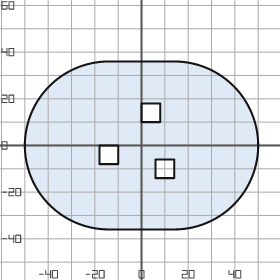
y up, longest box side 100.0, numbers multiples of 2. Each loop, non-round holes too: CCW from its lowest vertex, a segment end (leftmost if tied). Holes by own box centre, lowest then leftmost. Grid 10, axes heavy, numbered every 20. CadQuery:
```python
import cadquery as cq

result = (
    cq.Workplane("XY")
    .moveTo(-14.0, -36.0)
    .lineTo(14.0, -36.0)
    .threePointArc((50.0, 0.0), (14.0, 36.0))
    .lineTo(-14.0, 36.0)
    .threePointArc((-50.0, 0.0), (-14.0, -36.0))
    .close()
    .moveTo(6.0, -14.0)
    .lineTo(14.0, -14.0)
    .lineTo(14.0, -6.0)
    .lineTo(6.0, -6.0)
    .close()
    .moveTo(-18.0, -8.0)
    .lineTo(-10.0, -8.0)
    .lineTo(-10.0, 0.0)
    .lineTo(-18.0, 0.0)
    .close()
    .moveTo(0.0, 10.0)
    .lineTo(8.0, 10.0)
    .lineTo(8.0, 18.0)
    .lineTo(0.0, 18.0)
    .close()
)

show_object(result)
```